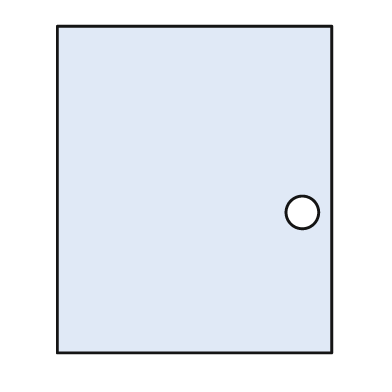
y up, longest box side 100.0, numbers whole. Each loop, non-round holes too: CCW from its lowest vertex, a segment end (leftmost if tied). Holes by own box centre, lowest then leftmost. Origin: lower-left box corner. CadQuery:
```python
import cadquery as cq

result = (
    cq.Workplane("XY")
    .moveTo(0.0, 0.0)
    .lineTo(84.0, 0.0)
    .lineTo(84.0, 100.0)
    .lineTo(0.0, 100.0)
    .close()
    .moveTo(75.0, 43.0)
    .circle(5.0)
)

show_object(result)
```